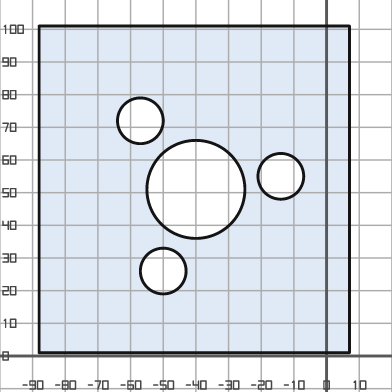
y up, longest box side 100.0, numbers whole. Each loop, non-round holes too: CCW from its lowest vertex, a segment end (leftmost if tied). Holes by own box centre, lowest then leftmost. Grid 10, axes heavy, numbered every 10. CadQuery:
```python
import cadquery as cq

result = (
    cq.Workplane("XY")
    .moveTo(-88.0, 1.0)
    .lineTo(7.0, 1.0)
    .lineTo(7.0, 101.0)
    .lineTo(-88.0, 101.0)
    .close()
    .moveTo(-50.0, 26.0)
    .circle(7.0)
    .moveTo(-40.0, 51.0)
    .circle(15.0)
    .moveTo(-14.0, 55.0)
    .circle(7.0)
    .moveTo(-57.0, 72.0)
    .circle(7.0)
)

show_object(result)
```